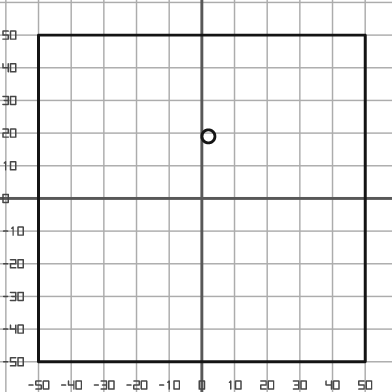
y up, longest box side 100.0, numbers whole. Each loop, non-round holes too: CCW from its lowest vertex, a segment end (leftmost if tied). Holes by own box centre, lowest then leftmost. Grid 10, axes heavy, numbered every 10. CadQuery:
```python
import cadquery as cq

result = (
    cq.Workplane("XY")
    .moveTo(-50.0, -50.0)
    .lineTo(50.0, -50.0)
    .lineTo(50.0, 50.0)
    .lineTo(-50.0, 50.0)
    .close()
    .moveTo(2.0, 19.0)
    .circle(2.0)
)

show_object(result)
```